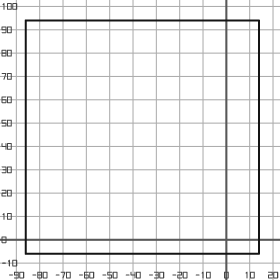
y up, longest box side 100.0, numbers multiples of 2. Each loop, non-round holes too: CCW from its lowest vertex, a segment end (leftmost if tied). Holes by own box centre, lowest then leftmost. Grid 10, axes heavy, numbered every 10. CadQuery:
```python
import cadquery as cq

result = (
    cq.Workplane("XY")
    .moveTo(-86.0, -6.0)
    .lineTo(14.0, -6.0)
    .lineTo(14.0, 94.0)
    .lineTo(-86.0, 94.0)
    .close()
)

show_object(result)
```